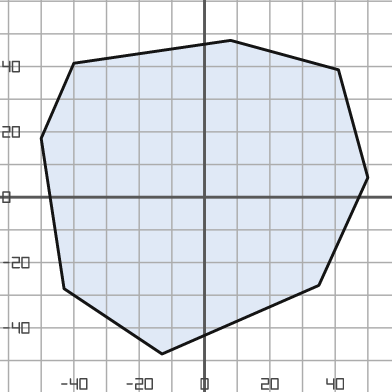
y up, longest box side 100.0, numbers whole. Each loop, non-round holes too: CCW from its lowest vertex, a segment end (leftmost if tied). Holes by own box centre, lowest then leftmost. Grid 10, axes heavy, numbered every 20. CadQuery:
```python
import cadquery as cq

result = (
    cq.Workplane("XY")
    .moveTo(-13.0, -48.0)
    .lineTo(35.0, -27.0)
    .lineTo(50.0, 6.0)
    .lineTo(41.0, 39.0)
    .lineTo(8.0, 48.0)
    .lineTo(-40.0, 41.0)
    .lineTo(-50.0, 18.0)
    .lineTo(-43.0, -28.0)
    .close()
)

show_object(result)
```